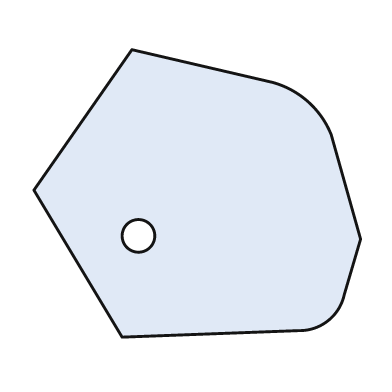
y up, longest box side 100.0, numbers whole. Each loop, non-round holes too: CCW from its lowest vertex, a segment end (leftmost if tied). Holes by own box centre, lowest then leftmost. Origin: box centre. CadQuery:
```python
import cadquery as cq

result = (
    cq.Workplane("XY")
    .moveTo(-23.0, -44.0)
    .lineTo(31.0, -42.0)
    .threePointArc((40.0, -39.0), (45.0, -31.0))
    .lineTo(50.0, -14.0)
    .lineTo(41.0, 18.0)
    .threePointArc((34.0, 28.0), (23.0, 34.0))
    .lineTo(-20.0, 44.0)
    .lineTo(-50.0, 1.0)
    .close()
    .moveTo(-18.0, -13.0)
    .circle(5.0)
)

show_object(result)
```